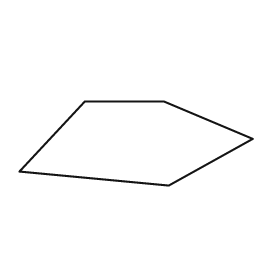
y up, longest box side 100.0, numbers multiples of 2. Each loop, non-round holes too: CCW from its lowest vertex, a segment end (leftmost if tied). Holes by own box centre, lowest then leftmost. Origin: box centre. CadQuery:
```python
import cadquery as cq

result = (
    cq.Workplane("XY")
    .moveTo(14.0, -18.0)
    .lineTo(50.0, 2.0)
    .lineTo(12.0, 18.0)
    .lineTo(-22.0, 18.0)
    .lineTo(-50.0, -12.0)
    .close()
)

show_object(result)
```